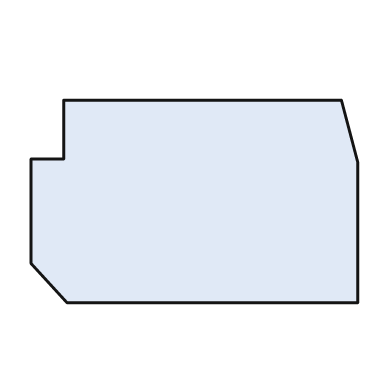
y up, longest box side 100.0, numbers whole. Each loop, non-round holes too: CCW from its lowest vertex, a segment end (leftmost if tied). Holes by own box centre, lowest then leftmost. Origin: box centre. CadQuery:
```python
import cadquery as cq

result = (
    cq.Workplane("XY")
    .moveTo(-39.0, -31.0)
    .lineTo(50.0, -31.0)
    .lineTo(50.0, 12.0)
    .lineTo(45.0, 31.0)
    .lineTo(-40.0, 31.0)
    .lineTo(-40.0, 13.0)
    .lineTo(-50.0, 13.0)
    .lineTo(-50.0, -19.0)
    .close()
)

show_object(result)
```